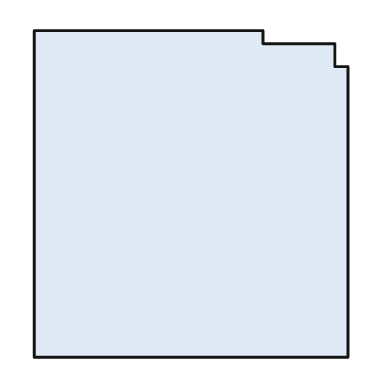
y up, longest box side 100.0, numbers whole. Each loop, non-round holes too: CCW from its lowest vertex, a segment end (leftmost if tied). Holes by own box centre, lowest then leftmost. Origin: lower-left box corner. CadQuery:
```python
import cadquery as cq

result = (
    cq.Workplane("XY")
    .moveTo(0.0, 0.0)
    .lineTo(96.0, 0.0)
    .lineTo(96.0, 89.0)
    .lineTo(92.0, 89.0)
    .lineTo(92.0, 96.0)
    .lineTo(70.0, 96.0)
    .lineTo(70.0, 100.0)
    .lineTo(0.0, 100.0)
    .close()
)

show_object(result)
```